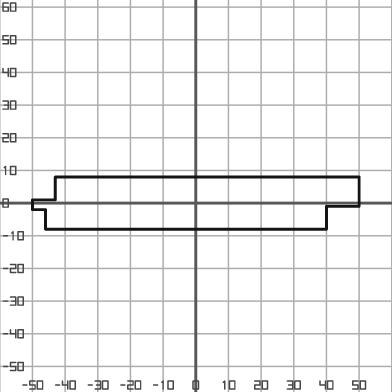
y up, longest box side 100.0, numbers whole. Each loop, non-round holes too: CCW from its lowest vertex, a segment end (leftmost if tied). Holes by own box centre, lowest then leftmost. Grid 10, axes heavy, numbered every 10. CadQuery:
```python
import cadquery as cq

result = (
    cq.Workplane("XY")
    .moveTo(-46.0, -8.0)
    .lineTo(40.0, -8.0)
    .lineTo(40.0, -1.0)
    .lineTo(50.0, -1.0)
    .lineTo(50.0, 8.0)
    .lineTo(-43.0, 8.0)
    .lineTo(-43.0, 1.0)
    .lineTo(-50.0, 1.0)
    .lineTo(-50.0, -2.0)
    .lineTo(-46.0, -2.0)
    .close()
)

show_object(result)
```